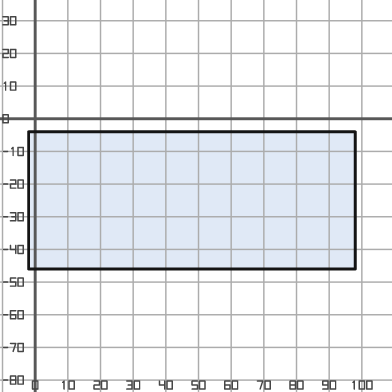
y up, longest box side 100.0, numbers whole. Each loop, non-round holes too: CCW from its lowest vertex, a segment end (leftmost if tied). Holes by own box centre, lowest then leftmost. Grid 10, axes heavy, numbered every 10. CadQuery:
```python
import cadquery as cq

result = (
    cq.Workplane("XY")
    .moveTo(-2.0, -46.0)
    .lineTo(98.0, -46.0)
    .lineTo(98.0, -4.0)
    .lineTo(-2.0, -4.0)
    .close()
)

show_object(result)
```